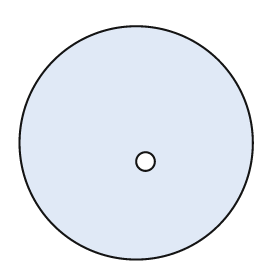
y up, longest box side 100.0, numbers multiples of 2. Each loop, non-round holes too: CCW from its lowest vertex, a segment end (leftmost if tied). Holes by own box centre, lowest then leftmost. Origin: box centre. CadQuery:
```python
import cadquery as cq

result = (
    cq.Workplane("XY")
    .moveTo(0.0, 0.0)
    .circle(50.0)
    .moveTo(4.0, -8.0)
    .circle(4.0)
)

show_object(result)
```